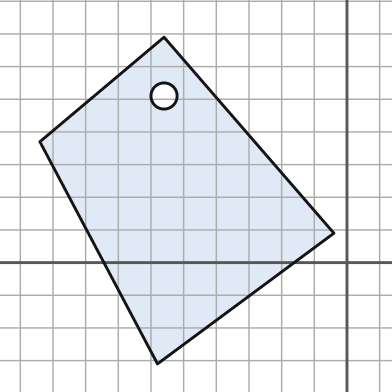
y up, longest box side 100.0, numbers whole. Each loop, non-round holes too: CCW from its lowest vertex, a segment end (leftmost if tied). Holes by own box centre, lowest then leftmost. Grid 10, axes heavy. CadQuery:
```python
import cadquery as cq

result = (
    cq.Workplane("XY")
    .moveTo(-58.0, -31.0)
    .lineTo(-4.0, 9.0)
    .lineTo(-56.0, 69.0)
    .lineTo(-94.0, 37.0)
    .close()
    .moveTo(-56.0, 51.0)
    .circle(4.0)
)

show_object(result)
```